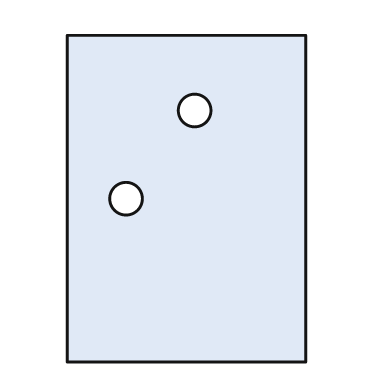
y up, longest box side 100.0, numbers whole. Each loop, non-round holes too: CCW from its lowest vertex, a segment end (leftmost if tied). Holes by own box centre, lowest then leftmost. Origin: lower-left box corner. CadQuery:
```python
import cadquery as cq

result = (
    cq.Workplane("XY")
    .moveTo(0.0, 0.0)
    .lineTo(73.0, 0.0)
    .lineTo(73.0, 100.0)
    .lineTo(0.0, 100.0)
    .close()
    .moveTo(18.0, 50.0)
    .circle(5.0)
    .moveTo(39.0, 77.0)
    .circle(5.0)
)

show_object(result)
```